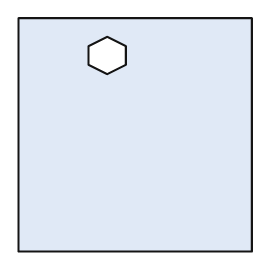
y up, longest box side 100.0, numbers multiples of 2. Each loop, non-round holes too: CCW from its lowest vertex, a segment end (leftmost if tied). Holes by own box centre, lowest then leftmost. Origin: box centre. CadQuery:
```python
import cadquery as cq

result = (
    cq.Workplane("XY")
    .moveTo(-50.0, -50.0)
    .lineTo(50.0, -50.0)
    .lineTo(50.0, 50.0)
    .lineTo(-50.0, 50.0)
    .close()
    .moveTo(-12.0, 26.0)
    .lineTo(-4.0, 30.0)
    .lineTo(-4.0, 38.0)
    .lineTo(-12.0, 42.0)
    .lineTo(-20.0, 38.0)
    .lineTo(-20.0, 30.0)
    .close()
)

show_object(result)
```